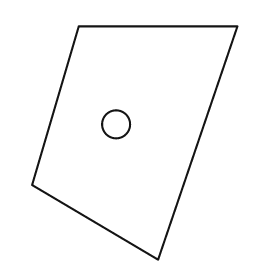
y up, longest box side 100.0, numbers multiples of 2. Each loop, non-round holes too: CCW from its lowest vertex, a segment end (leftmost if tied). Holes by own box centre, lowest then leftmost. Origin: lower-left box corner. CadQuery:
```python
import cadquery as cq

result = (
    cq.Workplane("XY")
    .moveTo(54.0, 0.0)
    .lineTo(88.0, 100.0)
    .lineTo(20.0, 100.0)
    .lineTo(0.0, 32.0)
    .close()
    .moveTo(36.0, 58.0)
    .circle(6.0)
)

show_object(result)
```